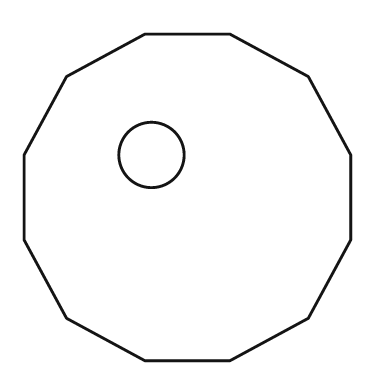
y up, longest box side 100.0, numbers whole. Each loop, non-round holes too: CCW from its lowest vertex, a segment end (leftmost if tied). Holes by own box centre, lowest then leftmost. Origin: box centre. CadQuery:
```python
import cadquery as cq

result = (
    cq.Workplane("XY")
    .moveTo(-13.0, -50.0)
    .lineTo(13.0, -50.0)
    .lineTo(37.0, -37.0)
    .lineTo(50.0, -13.0)
    .lineTo(50.0, 13.0)
    .lineTo(37.0, 37.0)
    .lineTo(13.0, 50.0)
    .lineTo(-13.0, 50.0)
    .lineTo(-37.0, 37.0)
    .lineTo(-50.0, 13.0)
    .lineTo(-50.0, -13.0)
    .lineTo(-37.0, -37.0)
    .close()
    .moveTo(-11.0, 13.0)
    .circle(10.0)
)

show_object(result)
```